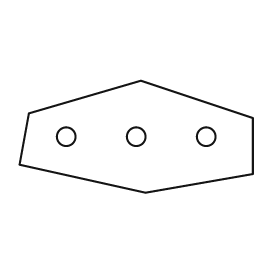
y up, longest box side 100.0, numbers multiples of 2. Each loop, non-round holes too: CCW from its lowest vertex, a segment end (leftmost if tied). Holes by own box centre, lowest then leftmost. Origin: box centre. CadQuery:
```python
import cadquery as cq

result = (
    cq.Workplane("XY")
    .moveTo(4.0, -24.0)
    .lineTo(50.0, -16.0)
    .lineTo(50.0, 8.0)
    .lineTo(2.0, 24.0)
    .lineTo(-46.0, 10.0)
    .lineTo(-50.0, -12.0)
    .close()
    .moveTo(-30.0, 0.0)
    .circle(4.0)
    .moveTo(0.0, 0.0)
    .circle(4.0)
    .moveTo(30.0, 0.0)
    .circle(4.0)
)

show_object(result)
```